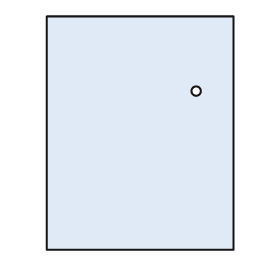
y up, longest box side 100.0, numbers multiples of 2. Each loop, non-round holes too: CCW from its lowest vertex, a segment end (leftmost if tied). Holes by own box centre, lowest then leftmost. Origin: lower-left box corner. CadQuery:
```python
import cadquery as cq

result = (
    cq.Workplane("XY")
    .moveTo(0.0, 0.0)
    .lineTo(80.0, 0.0)
    .lineTo(80.0, 100.0)
    .lineTo(0.0, 100.0)
    .close()
    .moveTo(64.0, 68.0)
    .circle(2.0)
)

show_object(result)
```